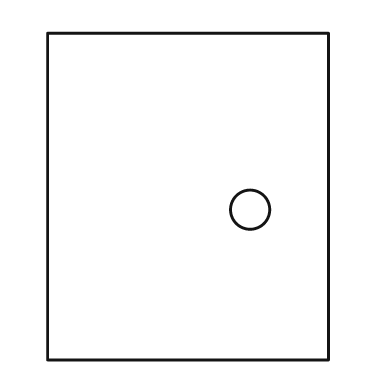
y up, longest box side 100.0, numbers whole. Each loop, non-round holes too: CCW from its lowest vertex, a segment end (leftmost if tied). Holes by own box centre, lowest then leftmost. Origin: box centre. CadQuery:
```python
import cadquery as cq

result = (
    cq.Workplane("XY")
    .moveTo(-43.0, -50.0)
    .lineTo(43.0, -50.0)
    .lineTo(43.0, 50.0)
    .lineTo(-43.0, 50.0)
    .close()
    .moveTo(19.0, -4.0)
    .circle(6.0)
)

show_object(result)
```